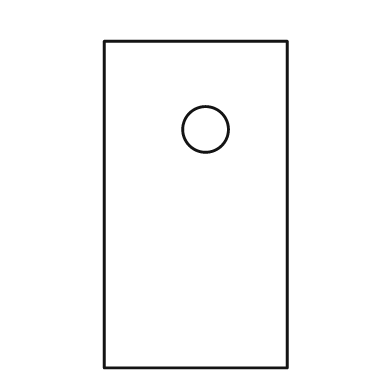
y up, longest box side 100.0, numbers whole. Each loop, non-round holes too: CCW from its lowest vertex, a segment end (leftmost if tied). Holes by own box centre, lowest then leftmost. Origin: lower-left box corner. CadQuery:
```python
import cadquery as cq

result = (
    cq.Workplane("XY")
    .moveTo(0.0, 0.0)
    .lineTo(56.0, 0.0)
    .lineTo(56.0, 100.0)
    .lineTo(0.0, 100.0)
    .close()
    .moveTo(31.0, 73.0)
    .circle(7.0)
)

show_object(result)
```